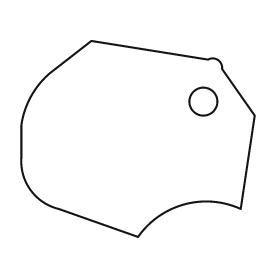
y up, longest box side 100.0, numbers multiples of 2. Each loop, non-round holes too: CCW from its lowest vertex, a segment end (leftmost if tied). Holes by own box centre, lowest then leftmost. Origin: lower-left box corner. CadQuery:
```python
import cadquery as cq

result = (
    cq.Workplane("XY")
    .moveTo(50.0, 0.0)
    .threePointArc((70.0, 14.0), (94.0, 12.0))
    .lineTo(100.0, 52.0)
    .lineTo(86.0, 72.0)
    .threePointArc((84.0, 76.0), (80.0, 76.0))
    .lineTo(30.0, 84.0)
    .lineTo(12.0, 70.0)
    .threePointArc((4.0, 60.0), (0.0, 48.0))
    .lineTo(0.0, 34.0)
    .threePointArc((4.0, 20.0), (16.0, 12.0))
    .close()
    .moveTo(78.0, 58.0)
    .circle(6.0)
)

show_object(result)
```